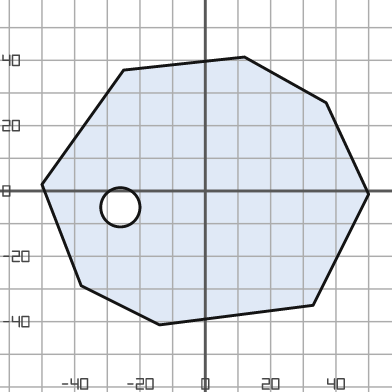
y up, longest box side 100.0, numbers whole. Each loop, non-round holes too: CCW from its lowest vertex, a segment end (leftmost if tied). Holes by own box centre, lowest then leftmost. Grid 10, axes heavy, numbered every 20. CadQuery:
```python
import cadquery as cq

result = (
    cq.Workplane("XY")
    .moveTo(-14.0, -41.0)
    .lineTo(33.0, -35.0)
    .lineTo(50.0, -1.0)
    .lineTo(37.0, 27.0)
    .lineTo(12.0, 41.0)
    .lineTo(-25.0, 37.0)
    .lineTo(-50.0, 2.0)
    .lineTo(-38.0, -29.0)
    .close()
    .moveTo(-26.0, -5.0)
    .circle(6.0)
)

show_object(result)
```